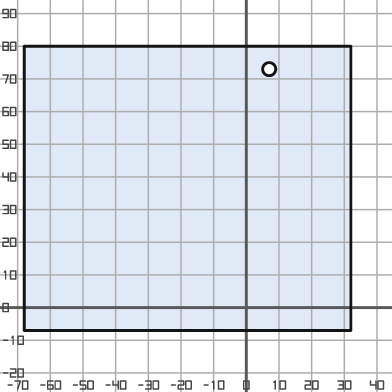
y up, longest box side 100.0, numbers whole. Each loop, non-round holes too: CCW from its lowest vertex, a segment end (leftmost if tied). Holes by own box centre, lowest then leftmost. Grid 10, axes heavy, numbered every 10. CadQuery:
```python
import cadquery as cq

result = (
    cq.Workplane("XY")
    .moveTo(-68.0, -7.0)
    .lineTo(32.0, -7.0)
    .lineTo(32.0, 80.0)
    .lineTo(-68.0, 80.0)
    .close()
    .moveTo(7.0, 73.0)
    .circle(2.0)
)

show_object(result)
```